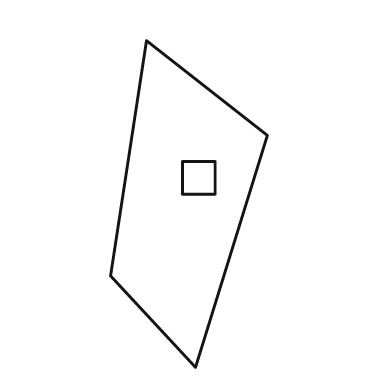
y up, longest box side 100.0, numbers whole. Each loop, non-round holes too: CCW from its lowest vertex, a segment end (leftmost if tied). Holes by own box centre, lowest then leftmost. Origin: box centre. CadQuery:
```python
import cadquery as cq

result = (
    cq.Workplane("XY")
    .moveTo(2.0, -50.0)
    .lineTo(24.0, 21.0)
    .lineTo(-13.0, 50.0)
    .lineTo(-24.0, -22.0)
    .close()
    .moveTo(-2.0, 3.0)
    .lineTo(8.0, 3.0)
    .lineTo(8.0, 13.0)
    .lineTo(-2.0, 13.0)
    .close()
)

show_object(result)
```